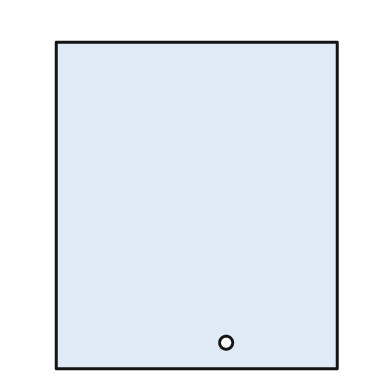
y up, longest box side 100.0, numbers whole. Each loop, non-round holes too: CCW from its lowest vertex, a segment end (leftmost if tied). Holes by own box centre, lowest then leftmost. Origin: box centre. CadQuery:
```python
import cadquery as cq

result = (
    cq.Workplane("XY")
    .moveTo(-43.0, -50.0)
    .lineTo(43.0, -50.0)
    .lineTo(43.0, 50.0)
    .lineTo(-43.0, 50.0)
    .close()
    .moveTo(9.0, -42.0)
    .circle(2.0)
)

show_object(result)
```